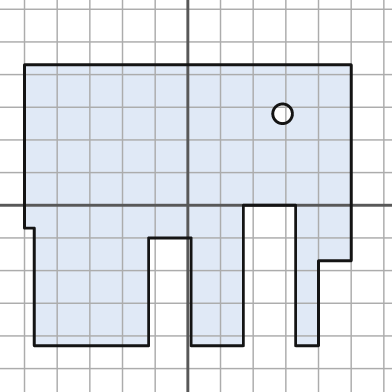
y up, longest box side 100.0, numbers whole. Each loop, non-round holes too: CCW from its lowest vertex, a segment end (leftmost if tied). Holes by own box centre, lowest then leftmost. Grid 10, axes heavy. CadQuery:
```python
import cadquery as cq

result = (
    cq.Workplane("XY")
    .moveTo(-47.0, -43.0)
    .lineTo(-12.0, -43.0)
    .lineTo(-12.0, -10.0)
    .lineTo(1.0, -10.0)
    .lineTo(1.0, -43.0)
    .lineTo(17.0, -43.0)
    .lineTo(17.0, 0.0)
    .lineTo(33.0, 0.0)
    .lineTo(33.0, -43.0)
    .lineTo(40.0, -43.0)
    .lineTo(40.0, -17.0)
    .lineTo(50.0, -17.0)
    .lineTo(50.0, 43.0)
    .lineTo(-50.0, 43.0)
    .lineTo(-50.0, -7.0)
    .lineTo(-47.0, -7.0)
    .close()
    .moveTo(29.0, 28.0)
    .circle(3.0)
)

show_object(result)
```